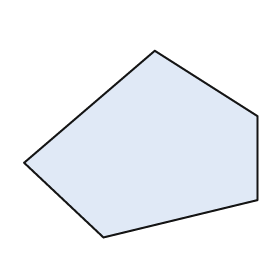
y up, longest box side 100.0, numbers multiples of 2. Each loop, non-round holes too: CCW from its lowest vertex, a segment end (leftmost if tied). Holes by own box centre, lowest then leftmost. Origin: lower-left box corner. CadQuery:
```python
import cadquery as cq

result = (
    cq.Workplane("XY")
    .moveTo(34.0, 0.0)
    .lineTo(100.0, 16.0)
    .lineTo(100.0, 52.0)
    .lineTo(56.0, 80.0)
    .lineTo(0.0, 32.0)
    .close()
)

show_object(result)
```